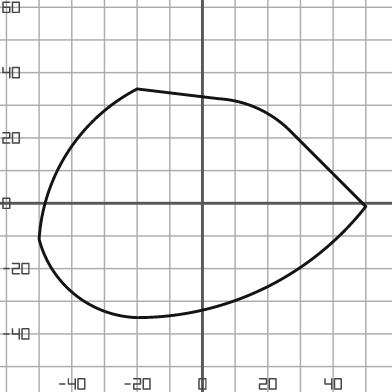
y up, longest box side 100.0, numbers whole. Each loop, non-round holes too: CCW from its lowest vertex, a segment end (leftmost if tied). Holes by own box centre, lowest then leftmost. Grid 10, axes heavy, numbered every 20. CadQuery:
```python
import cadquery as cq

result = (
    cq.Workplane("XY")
    .moveTo(-20.0, -35.0)
    .threePointArc((19.0, -26.0), (50.0, -1.0))
    .lineTo(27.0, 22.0)
    .threePointArc((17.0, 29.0), (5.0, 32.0))
    .lineTo(-20.0, 35.0)
    .threePointArc((-41.0, 16.0), (-50.0, -11.0))
    .threePointArc((-39.0, -28.0), (-20.0, -35.0))
    .close()
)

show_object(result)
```